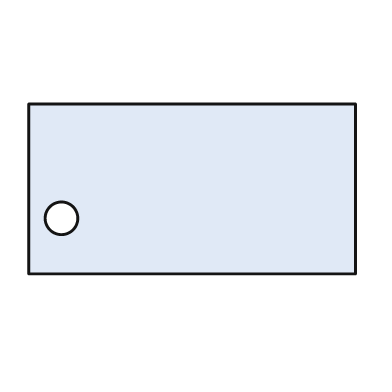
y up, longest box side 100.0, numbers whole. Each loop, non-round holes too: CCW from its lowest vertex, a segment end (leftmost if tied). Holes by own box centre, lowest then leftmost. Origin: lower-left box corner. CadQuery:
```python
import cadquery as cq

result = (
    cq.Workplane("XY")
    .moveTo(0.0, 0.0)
    .lineTo(100.0, 0.0)
    .lineTo(100.0, 52.0)
    .lineTo(0.0, 52.0)
    .close()
    .moveTo(10.0, 17.0)
    .circle(5.0)
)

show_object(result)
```